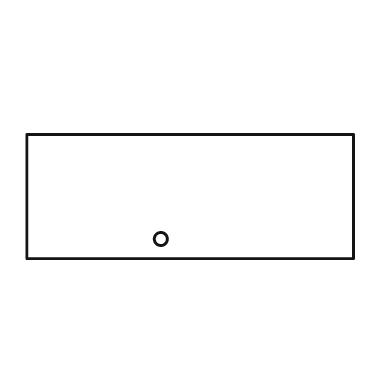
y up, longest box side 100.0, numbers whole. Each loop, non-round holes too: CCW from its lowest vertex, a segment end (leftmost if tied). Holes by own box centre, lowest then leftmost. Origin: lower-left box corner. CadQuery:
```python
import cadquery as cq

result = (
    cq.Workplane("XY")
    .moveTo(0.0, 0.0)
    .lineTo(100.0, 0.0)
    .lineTo(100.0, 38.0)
    .lineTo(0.0, 38.0)
    .close()
    .moveTo(41.0, 6.0)
    .circle(2.0)
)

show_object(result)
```